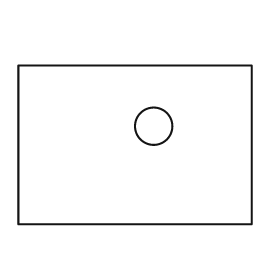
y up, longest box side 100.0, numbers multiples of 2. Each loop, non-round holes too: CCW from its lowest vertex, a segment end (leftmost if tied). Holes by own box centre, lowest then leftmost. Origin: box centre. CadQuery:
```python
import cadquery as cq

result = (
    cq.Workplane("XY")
    .moveTo(-50.0, -34.0)
    .lineTo(50.0, -34.0)
    .lineTo(50.0, 34.0)
    .lineTo(-50.0, 34.0)
    .close()
    .moveTo(8.0, 8.0)
    .circle(8.0)
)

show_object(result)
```